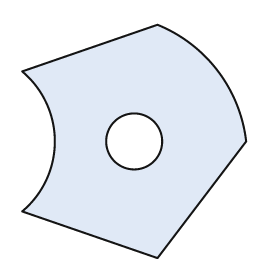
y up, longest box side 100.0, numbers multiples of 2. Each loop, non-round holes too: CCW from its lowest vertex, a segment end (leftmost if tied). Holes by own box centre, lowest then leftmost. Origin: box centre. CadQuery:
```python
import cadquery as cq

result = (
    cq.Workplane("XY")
    .moveTo(10.0, -50.0)
    .lineTo(48.0, 0.0)
    .threePointArc((36.0, 30.0), (10.0, 50.0))
    .lineTo(-48.0, 30.0)
    .threePointArc((-34.0, 0.0), (-48.0, -30.0))
    .close()
    .moveTo(0.0, 0.0)
    .circle(12.0)
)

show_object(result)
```